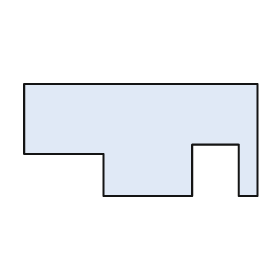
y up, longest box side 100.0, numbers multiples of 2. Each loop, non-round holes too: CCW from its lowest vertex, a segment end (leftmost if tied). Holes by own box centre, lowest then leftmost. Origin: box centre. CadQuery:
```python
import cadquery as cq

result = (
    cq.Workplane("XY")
    .moveTo(-16.0, -24.0)
    .lineTo(22.0, -24.0)
    .lineTo(22.0, -2.0)
    .lineTo(42.0, -2.0)
    .lineTo(42.0, -24.0)
    .lineTo(50.0, -24.0)
    .lineTo(50.0, 24.0)
    .lineTo(-50.0, 24.0)
    .lineTo(-50.0, -6.0)
    .lineTo(-16.0, -6.0)
    .close()
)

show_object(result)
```